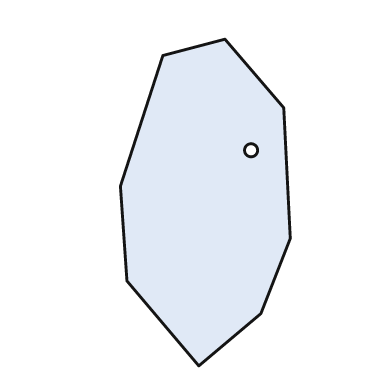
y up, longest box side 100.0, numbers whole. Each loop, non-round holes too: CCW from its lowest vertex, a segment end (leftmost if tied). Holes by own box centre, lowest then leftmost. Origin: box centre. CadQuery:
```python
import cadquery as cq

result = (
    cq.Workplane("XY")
    .moveTo(-2.0, -50.0)
    .lineTo(17.0, -34.0)
    .lineTo(26.0, -11.0)
    .lineTo(24.0, 29.0)
    .lineTo(6.0, 50.0)
    .lineTo(-13.0, 45.0)
    .lineTo(-26.0, 5.0)
    .lineTo(-24.0, -24.0)
    .close()
    .moveTo(14.0, 16.0)
    .circle(2.0)
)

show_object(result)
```